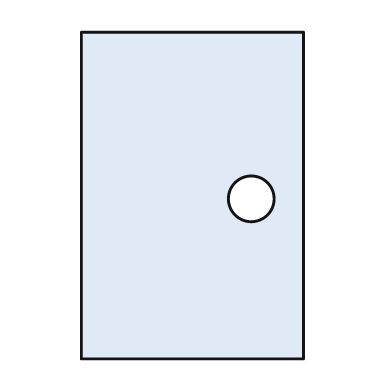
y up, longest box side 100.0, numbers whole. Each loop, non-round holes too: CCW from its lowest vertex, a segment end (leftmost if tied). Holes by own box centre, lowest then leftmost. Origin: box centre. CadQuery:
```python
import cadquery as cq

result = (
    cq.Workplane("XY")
    .moveTo(-34.0, -50.0)
    .lineTo(34.0, -50.0)
    .lineTo(34.0, 50.0)
    .lineTo(-34.0, 50.0)
    .close()
    .moveTo(18.0, -1.0)
    .circle(7.0)
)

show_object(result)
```